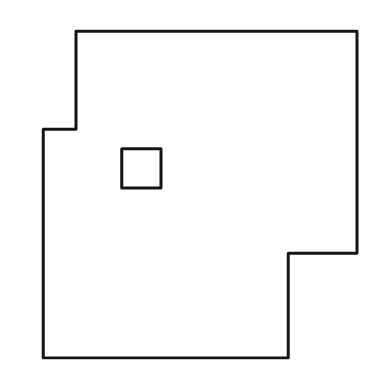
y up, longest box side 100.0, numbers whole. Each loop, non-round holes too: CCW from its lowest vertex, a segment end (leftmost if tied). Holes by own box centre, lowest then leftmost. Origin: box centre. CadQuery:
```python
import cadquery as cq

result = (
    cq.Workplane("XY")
    .moveTo(-48.0, -50.0)
    .lineTo(27.0, -50.0)
    .lineTo(27.0, -18.0)
    .lineTo(48.0, -18.0)
    .lineTo(48.0, 50.0)
    .lineTo(-38.0, 50.0)
    .lineTo(-38.0, 20.0)
    .lineTo(-48.0, 20.0)
    .close()
    .moveTo(-24.0, 2.0)
    .lineTo(-12.0, 2.0)
    .lineTo(-12.0, 14.0)
    .lineTo(-24.0, 14.0)
    .close()
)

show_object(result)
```